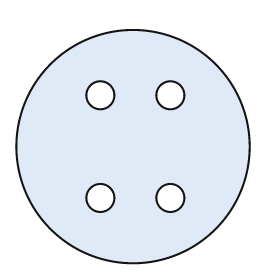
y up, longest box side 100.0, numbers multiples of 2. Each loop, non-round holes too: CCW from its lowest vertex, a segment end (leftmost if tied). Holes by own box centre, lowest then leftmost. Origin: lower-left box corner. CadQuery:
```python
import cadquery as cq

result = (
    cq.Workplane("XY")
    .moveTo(50.0, 50.0)
    .circle(50.0)
    .moveTo(36.0, 28.0)
    .circle(6.0)
    .moveTo(66.0, 28.0)
    .circle(6.0)
    .moveTo(36.0, 72.0)
    .circle(6.0)
    .moveTo(66.0, 72.0)
    .circle(6.0)
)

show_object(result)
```